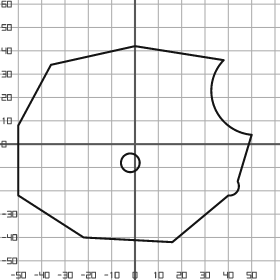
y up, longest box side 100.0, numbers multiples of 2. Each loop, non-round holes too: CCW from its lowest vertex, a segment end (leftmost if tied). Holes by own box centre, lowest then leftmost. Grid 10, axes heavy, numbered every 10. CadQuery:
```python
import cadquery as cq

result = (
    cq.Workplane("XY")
    .moveTo(16.0, -42.0)
    .lineTo(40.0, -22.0)
    .threePointArc((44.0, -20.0), (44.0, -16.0))
    .lineTo(50.0, 4.0)
    .threePointArc((34.0, 16.0), (38.0, 36.0))
    .lineTo(0.0, 42.0)
    .lineTo(-36.0, 34.0)
    .lineTo(-50.0, 8.0)
    .lineTo(-50.0, -22.0)
    .lineTo(-22.0, -40.0)
    .close()
    .moveTo(-2.0, -8.0)
    .circle(4.0)
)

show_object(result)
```